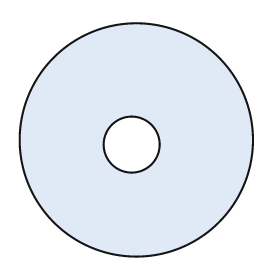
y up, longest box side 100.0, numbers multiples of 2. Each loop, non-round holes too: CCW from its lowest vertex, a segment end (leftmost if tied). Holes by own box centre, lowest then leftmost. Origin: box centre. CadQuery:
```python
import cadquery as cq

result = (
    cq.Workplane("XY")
    .moveTo(0.0, 0.0)
    .circle(50.0)
    .moveTo(-2.0, -2.0)
    .circle(12.0)
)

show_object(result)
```